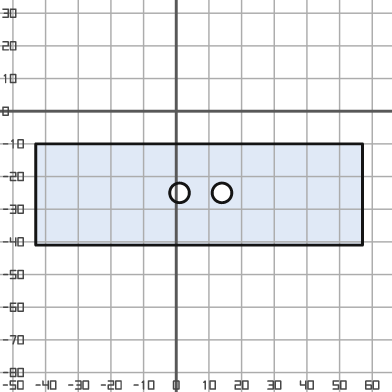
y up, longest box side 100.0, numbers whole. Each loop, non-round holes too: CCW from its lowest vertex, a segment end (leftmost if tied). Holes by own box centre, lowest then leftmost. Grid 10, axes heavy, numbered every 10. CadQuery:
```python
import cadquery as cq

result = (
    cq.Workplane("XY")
    .moveTo(-43.0, -41.0)
    .lineTo(57.0, -41.0)
    .lineTo(57.0, -10.0)
    .lineTo(-43.0, -10.0)
    .close()
    .moveTo(1.0, -25.0)
    .circle(3.0)
    .moveTo(14.0, -25.0)
    .circle(3.0)
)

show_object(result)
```